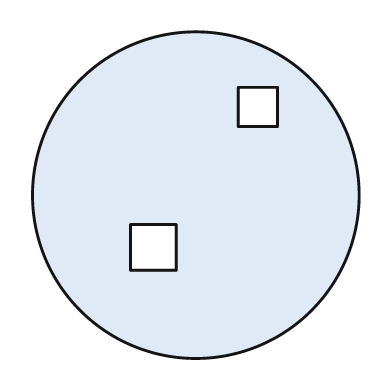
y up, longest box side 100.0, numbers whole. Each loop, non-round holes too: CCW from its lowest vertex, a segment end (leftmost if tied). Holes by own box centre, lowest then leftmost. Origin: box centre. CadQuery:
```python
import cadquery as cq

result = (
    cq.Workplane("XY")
    .moveTo(0.0, 0.0)
    .circle(50.0)
    .moveTo(-20.0, -23.0)
    .lineTo(-6.0, -23.0)
    .lineTo(-6.0, -9.0)
    .lineTo(-20.0, -9.0)
    .close()
    .moveTo(13.0, 21.0)
    .lineTo(25.0, 21.0)
    .lineTo(25.0, 33.0)
    .lineTo(13.0, 33.0)
    .close()
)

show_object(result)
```